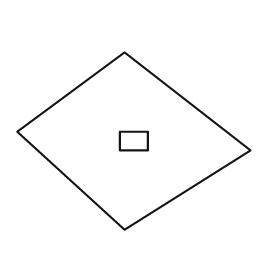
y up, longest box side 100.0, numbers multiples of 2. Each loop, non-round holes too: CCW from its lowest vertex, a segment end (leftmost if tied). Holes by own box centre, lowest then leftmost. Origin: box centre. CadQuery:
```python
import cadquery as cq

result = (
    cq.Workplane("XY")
    .moveTo(-4.0, -38.0)
    .lineTo(50.0, -4.0)
    .lineTo(-4.0, 38.0)
    .lineTo(-50.0, 4.0)
    .close()
    .moveTo(-6.0, -4.0)
    .lineTo(6.0, -4.0)
    .lineTo(6.0, 4.0)
    .lineTo(-6.0, 4.0)
    .close()
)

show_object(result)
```